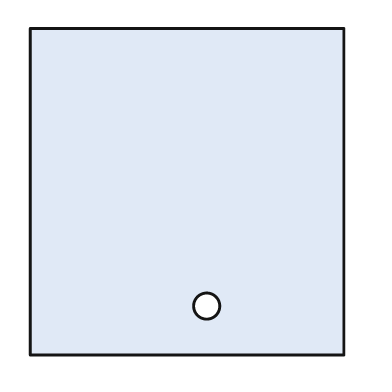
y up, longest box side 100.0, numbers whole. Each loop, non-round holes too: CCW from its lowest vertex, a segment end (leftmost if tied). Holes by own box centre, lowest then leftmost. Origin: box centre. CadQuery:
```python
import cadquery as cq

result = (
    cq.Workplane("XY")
    .moveTo(-48.0, -50.0)
    .lineTo(48.0, -50.0)
    .lineTo(48.0, 50.0)
    .lineTo(-48.0, 50.0)
    .close()
    .moveTo(6.0, -35.0)
    .circle(4.0)
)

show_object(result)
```